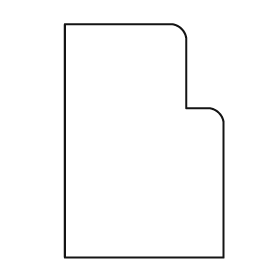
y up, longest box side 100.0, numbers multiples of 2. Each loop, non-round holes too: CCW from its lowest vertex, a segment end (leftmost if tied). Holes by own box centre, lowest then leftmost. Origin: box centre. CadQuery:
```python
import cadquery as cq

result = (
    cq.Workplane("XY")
    .moveTo(-34.0, -50.0)
    .lineTo(34.0, -50.0)
    .lineTo(34.0, 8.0)
    .threePointArc((32.0, 12.0), (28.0, 14.0))
    .lineTo(18.0, 14.0)
    .lineTo(18.0, 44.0)
    .threePointArc((16.0, 48.0), (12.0, 50.0))
    .lineTo(-34.0, 50.0)
    .close()
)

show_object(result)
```